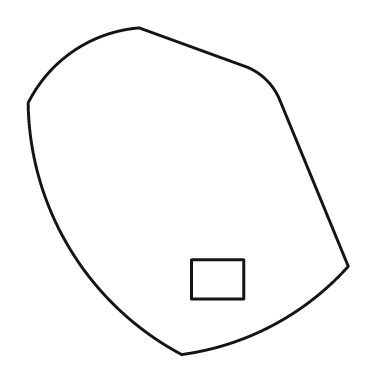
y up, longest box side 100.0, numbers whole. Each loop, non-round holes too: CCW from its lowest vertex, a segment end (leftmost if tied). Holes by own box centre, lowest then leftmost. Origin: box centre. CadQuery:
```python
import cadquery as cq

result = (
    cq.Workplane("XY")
    .moveTo(-2.0, -50.0)
    .threePointArc((26.0, -41.0), (49.0, -23.0))
    .lineTo(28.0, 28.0)
    .threePointArc((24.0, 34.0), (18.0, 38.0))
    .lineTo(-15.0, 50.0)
    .threePointArc((-35.0, 43.0), (-49.0, 27.0))
    .threePointArc((-36.0, -18.0), (-2.0, -50.0))
    .close()
    .moveTo(1.0, -33.0)
    .lineTo(17.0, -33.0)
    .lineTo(17.0, -21.0)
    .lineTo(1.0, -21.0)
    .close()
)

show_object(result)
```